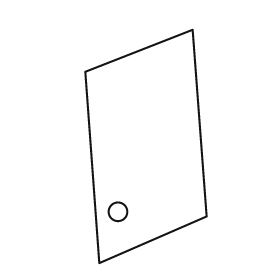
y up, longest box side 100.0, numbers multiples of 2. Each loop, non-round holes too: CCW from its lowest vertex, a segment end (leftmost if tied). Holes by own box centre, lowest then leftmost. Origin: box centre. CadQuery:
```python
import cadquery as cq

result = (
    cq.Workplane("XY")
    .moveTo(-20.0, -50.0)
    .lineTo(26.0, -30.0)
    .lineTo(20.0, 50.0)
    .lineTo(-26.0, 32.0)
    .close()
    .moveTo(-12.0, -28.0)
    .circle(4.0)
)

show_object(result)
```